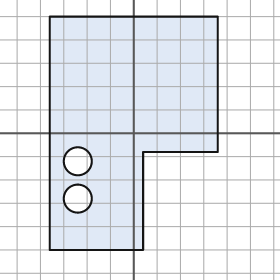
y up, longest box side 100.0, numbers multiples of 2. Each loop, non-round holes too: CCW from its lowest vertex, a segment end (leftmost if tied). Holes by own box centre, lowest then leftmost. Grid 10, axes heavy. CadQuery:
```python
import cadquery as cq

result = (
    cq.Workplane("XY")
    .moveTo(-36.0, -50.0)
    .lineTo(4.0, -50.0)
    .lineTo(4.0, -8.0)
    .lineTo(36.0, -8.0)
    .lineTo(36.0, 50.0)
    .lineTo(-36.0, 50.0)
    .close()
    .moveTo(-24.0, -28.0)
    .circle(6.0)
    .moveTo(-24.0, -12.0)
    .circle(6.0)
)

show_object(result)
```